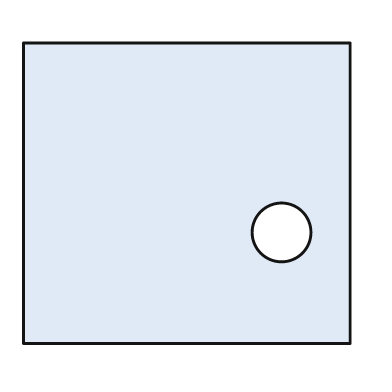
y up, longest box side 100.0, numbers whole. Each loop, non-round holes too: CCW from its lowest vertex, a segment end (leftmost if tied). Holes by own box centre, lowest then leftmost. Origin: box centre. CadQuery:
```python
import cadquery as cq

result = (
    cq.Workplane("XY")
    .moveTo(-50.0, -46.0)
    .lineTo(50.0, -46.0)
    .lineTo(50.0, 46.0)
    .lineTo(-50.0, 46.0)
    .close()
    .moveTo(29.0, -12.0)
    .circle(9.0)
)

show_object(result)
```